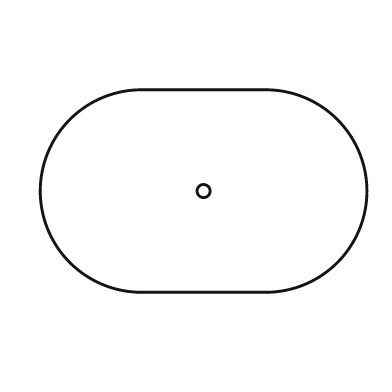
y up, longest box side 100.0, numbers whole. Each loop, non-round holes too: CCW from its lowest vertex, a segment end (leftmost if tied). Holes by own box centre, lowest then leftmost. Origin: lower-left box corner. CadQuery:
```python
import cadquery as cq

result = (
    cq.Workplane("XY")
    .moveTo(31.0, 0.0)
    .lineTo(69.0, 0.0)
    .threePointArc((100.0, 31.0), (69.0, 62.0))
    .lineTo(31.0, 62.0)
    .threePointArc((0.0, 31.0), (31.0, 0.0))
    .close()
    .moveTo(50.0, 31.0)
    .circle(2.0)
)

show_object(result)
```